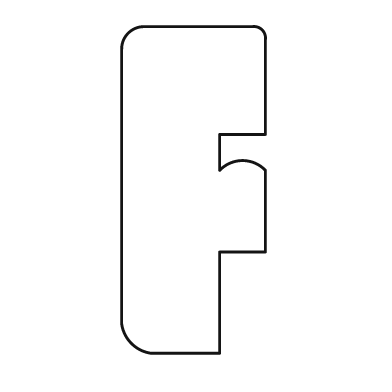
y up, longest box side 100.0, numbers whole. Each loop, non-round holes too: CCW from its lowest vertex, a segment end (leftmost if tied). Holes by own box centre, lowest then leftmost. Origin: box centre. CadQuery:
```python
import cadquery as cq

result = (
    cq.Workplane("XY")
    .moveTo(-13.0, -50.0)
    .lineTo(8.0, -50.0)
    .lineTo(8.0, -19.0)
    .lineTo(22.0, -19.0)
    .lineTo(22.0, 6.0)
    .threePointArc((15.0, 9.0), (8.0, 6.0))
    .lineTo(8.0, 17.0)
    .lineTo(22.0, 17.0)
    .lineTo(22.0, 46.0)
    .threePointArc((21.0, 49.0), (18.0, 50.0))
    .lineTo(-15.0, 50.0)
    .threePointArc((-20.0, 48.0), (-22.0, 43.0))
    .lineTo(-22.0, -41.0)
    .threePointArc((-19.0, -47.0), (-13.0, -50.0))
    .close()
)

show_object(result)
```